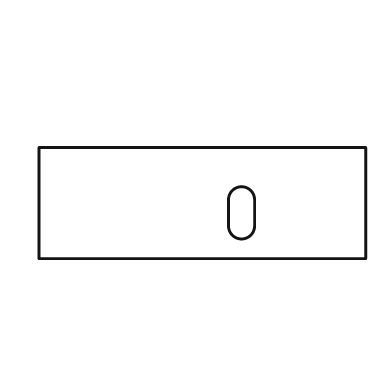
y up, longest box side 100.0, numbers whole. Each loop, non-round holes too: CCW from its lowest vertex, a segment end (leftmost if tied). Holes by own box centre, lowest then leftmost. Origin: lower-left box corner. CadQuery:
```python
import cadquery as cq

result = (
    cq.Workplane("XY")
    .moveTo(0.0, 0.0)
    .lineTo(100.0, 0.0)
    .lineTo(100.0, 34.0)
    .lineTo(0.0, 34.0)
    .close()
    .moveTo(58.0, 10.0)
    .threePointArc((62.0, 6.0), (66.0, 10.0))
    .lineTo(66.0, 18.0)
    .threePointArc((62.0, 22.0), (58.0, 18.0))
    .close()
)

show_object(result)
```